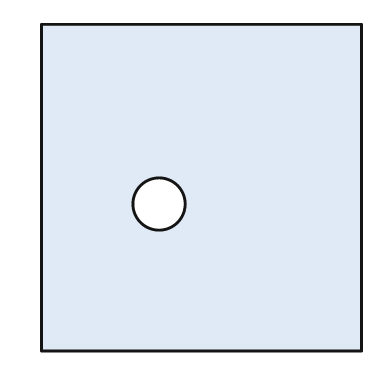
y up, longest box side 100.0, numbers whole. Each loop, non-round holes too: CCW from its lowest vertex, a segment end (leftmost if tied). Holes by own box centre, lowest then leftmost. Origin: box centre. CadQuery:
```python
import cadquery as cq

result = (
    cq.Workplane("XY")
    .moveTo(-49.0, -50.0)
    .lineTo(49.0, -50.0)
    .lineTo(49.0, 50.0)
    .lineTo(-49.0, 50.0)
    .close()
    .moveTo(-13.0, -5.0)
    .circle(8.0)
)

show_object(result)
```